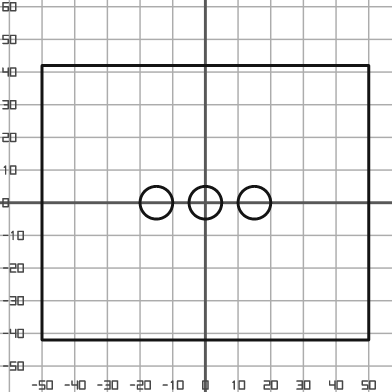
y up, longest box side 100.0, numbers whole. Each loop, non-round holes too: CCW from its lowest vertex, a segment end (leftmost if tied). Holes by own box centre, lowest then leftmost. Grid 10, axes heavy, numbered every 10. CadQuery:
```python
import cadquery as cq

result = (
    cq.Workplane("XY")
    .moveTo(-50.0, -42.0)
    .lineTo(50.0, -42.0)
    .lineTo(50.0, 42.0)
    .lineTo(-50.0, 42.0)
    .close()
    .moveTo(-15.0, 0.0)
    .circle(5.0)
    .moveTo(0.0, 0.0)
    .circle(5.0)
    .moveTo(15.0, 0.0)
    .circle(5.0)
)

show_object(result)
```